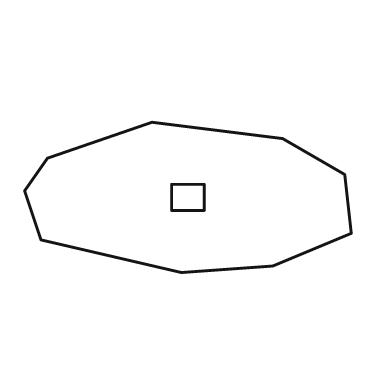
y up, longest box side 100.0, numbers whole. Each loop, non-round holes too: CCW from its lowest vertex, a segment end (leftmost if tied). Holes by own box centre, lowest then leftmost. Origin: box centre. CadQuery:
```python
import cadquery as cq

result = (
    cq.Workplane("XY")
    .moveTo(-2.0, -23.0)
    .lineTo(26.0, -21.0)
    .lineTo(50.0, -11.0)
    .lineTo(48.0, 7.0)
    .lineTo(29.0, 18.0)
    .lineTo(-11.0, 23.0)
    .lineTo(-43.0, 12.0)
    .lineTo(-50.0, 2.0)
    .lineTo(-45.0, -13.0)
    .close()
    .moveTo(-5.0, -4.0)
    .lineTo(5.0, -4.0)
    .lineTo(5.0, 4.0)
    .lineTo(-5.0, 4.0)
    .close()
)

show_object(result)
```